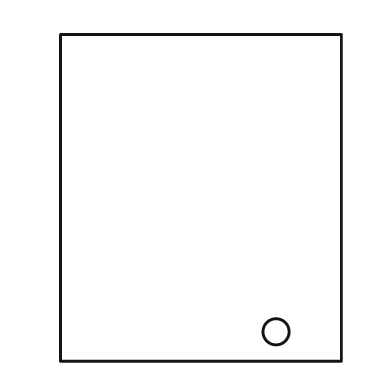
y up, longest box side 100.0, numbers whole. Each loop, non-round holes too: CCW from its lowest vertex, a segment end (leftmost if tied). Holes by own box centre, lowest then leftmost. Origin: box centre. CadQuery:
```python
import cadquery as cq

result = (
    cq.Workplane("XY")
    .moveTo(-43.0, -50.0)
    .lineTo(43.0, -50.0)
    .lineTo(43.0, 50.0)
    .lineTo(-43.0, 50.0)
    .close()
    .moveTo(23.0, -41.0)
    .circle(4.0)
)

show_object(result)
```